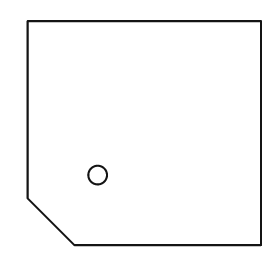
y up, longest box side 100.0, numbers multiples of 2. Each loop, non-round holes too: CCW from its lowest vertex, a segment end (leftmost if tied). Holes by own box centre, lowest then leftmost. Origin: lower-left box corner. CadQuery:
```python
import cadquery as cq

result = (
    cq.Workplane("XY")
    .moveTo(20.0, 0.0)
    .lineTo(100.0, 0.0)
    .lineTo(100.0, 96.0)
    .lineTo(0.0, 96.0)
    .lineTo(0.0, 20.0)
    .close()
    .moveTo(30.0, 30.0)
    .circle(4.0)
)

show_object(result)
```